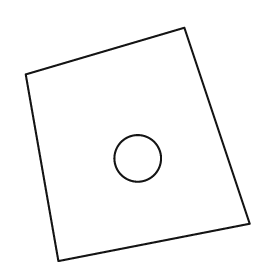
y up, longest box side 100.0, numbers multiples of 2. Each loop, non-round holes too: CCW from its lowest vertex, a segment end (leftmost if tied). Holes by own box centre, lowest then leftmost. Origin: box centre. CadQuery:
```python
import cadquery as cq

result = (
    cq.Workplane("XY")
    .moveTo(-34.0, -50.0)
    .lineTo(48.0, -34.0)
    .lineTo(20.0, 50.0)
    .lineTo(-48.0, 30.0)
    .close()
    .moveTo(0.0, -6.0)
    .circle(10.0)
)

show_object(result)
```